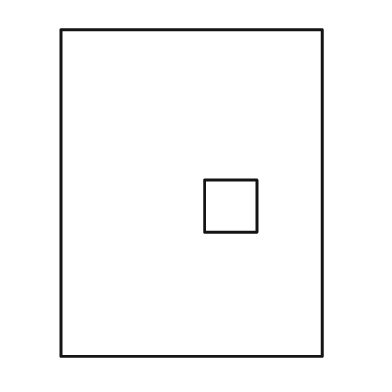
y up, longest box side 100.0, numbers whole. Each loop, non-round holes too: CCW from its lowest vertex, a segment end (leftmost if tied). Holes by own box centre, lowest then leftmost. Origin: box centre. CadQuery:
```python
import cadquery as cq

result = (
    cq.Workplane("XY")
    .moveTo(-40.0, -50.0)
    .lineTo(40.0, -50.0)
    .lineTo(40.0, 50.0)
    .lineTo(-40.0, 50.0)
    .close()
    .moveTo(4.0, -12.0)
    .lineTo(20.0, -12.0)
    .lineTo(20.0, 4.0)
    .lineTo(4.0, 4.0)
    .close()
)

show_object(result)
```